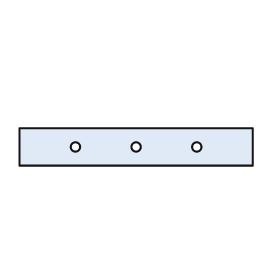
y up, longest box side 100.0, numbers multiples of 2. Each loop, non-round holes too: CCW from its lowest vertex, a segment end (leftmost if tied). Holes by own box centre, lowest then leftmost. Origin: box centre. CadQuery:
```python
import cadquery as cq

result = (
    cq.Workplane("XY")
    .moveTo(-50.0, -8.0)
    .lineTo(50.0, -8.0)
    .lineTo(50.0, 8.0)
    .lineTo(-50.0, 8.0)
    .close()
    .moveTo(-26.0, 0.0)
    .circle(2.0)
    .moveTo(0.0, 0.0)
    .circle(2.0)
    .moveTo(26.0, 0.0)
    .circle(2.0)
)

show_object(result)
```